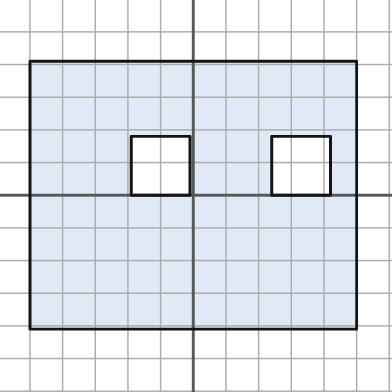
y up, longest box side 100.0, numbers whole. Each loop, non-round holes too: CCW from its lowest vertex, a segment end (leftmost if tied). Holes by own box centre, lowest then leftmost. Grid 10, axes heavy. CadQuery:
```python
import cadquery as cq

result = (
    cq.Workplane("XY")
    .moveTo(-50.0, -41.0)
    .lineTo(50.0, -41.0)
    .lineTo(50.0, 41.0)
    .lineTo(-50.0, 41.0)
    .close()
    .moveTo(-19.0, 0.0)
    .lineTo(-1.0, 0.0)
    .lineTo(-1.0, 18.0)
    .lineTo(-19.0, 18.0)
    .close()
    .moveTo(24.0, 0.0)
    .lineTo(42.0, 0.0)
    .lineTo(42.0, 18.0)
    .lineTo(24.0, 18.0)
    .close()
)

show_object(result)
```